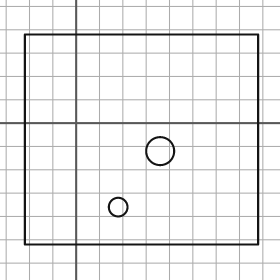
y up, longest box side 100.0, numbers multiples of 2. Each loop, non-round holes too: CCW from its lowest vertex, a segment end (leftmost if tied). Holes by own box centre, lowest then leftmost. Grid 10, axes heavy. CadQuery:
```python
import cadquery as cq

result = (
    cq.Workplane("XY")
    .moveTo(-22.0, -52.0)
    .lineTo(78.0, -52.0)
    .lineTo(78.0, 38.0)
    .lineTo(-22.0, 38.0)
    .close()
    .moveTo(18.0, -36.0)
    .circle(4.0)
    .moveTo(36.0, -12.0)
    .circle(6.0)
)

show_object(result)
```